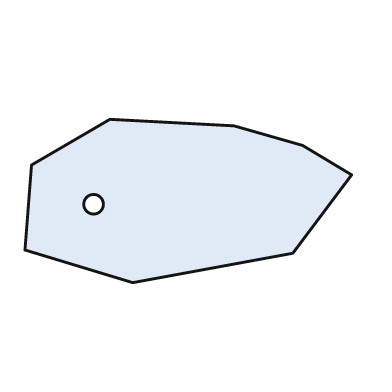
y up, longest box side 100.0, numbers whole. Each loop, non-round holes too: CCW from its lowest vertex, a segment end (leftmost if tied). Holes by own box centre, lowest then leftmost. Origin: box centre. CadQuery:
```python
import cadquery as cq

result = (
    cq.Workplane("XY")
    .moveTo(-17.0, -25.0)
    .lineTo(32.0, -16.0)
    .lineTo(50.0, 8.0)
    .lineTo(35.0, 17.0)
    .lineTo(14.0, 23.0)
    .lineTo(-24.0, 25.0)
    .lineTo(-48.0, 11.0)
    .lineTo(-50.0, -15.0)
    .close()
    .moveTo(-29.0, -1.0)
    .circle(3.0)
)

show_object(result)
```